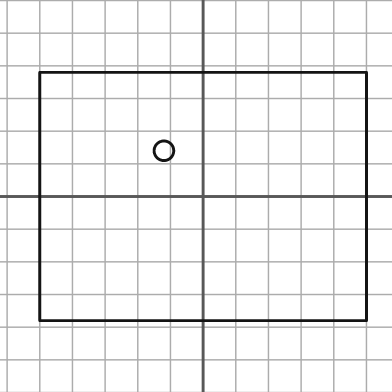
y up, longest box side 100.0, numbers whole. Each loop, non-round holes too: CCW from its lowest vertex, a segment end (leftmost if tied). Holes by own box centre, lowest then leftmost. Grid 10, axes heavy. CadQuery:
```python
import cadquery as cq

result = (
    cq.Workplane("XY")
    .moveTo(-50.0, -38.0)
    .lineTo(50.0, -38.0)
    .lineTo(50.0, 38.0)
    .lineTo(-50.0, 38.0)
    .close()
    .moveTo(-12.0, 14.0)
    .circle(3.0)
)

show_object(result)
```